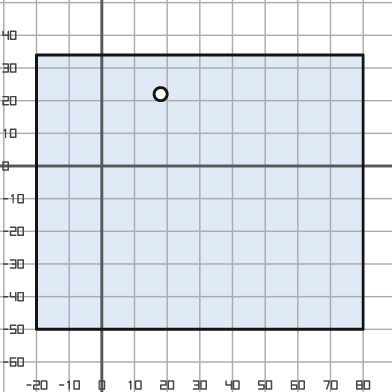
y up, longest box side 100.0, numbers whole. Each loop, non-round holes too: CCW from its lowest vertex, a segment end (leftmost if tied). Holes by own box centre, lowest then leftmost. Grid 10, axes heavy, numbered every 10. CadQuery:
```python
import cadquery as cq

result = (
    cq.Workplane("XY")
    .moveTo(-20.0, -50.0)
    .lineTo(80.0, -50.0)
    .lineTo(80.0, 34.0)
    .lineTo(-20.0, 34.0)
    .close()
    .moveTo(18.0, 22.0)
    .circle(2.0)
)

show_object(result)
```